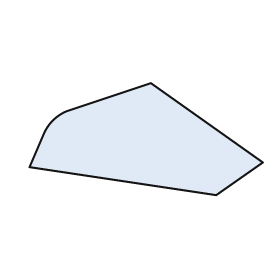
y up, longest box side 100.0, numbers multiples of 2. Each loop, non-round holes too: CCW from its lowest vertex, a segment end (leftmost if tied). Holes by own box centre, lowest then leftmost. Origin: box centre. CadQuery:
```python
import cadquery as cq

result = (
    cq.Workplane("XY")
    .moveTo(30.0, -24.0)
    .lineTo(50.0, -10.0)
    .lineTo(2.0, 24.0)
    .lineTo(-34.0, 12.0)
    .threePointArc((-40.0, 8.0), (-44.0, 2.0))
    .lineTo(-50.0, -12.0)
    .close()
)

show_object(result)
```